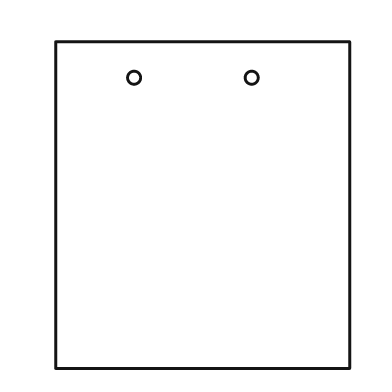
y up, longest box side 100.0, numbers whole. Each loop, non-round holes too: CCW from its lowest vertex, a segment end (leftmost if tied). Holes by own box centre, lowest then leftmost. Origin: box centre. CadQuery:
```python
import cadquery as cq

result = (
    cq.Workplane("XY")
    .moveTo(-45.0, -50.0)
    .lineTo(45.0, -50.0)
    .lineTo(45.0, 50.0)
    .lineTo(-45.0, 50.0)
    .close()
    .moveTo(-21.0, 39.0)
    .circle(2.0)
    .moveTo(15.0, 39.0)
    .circle(2.0)
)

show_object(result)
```